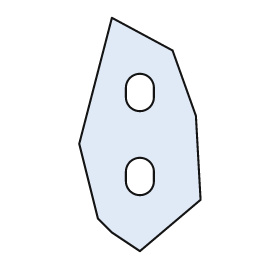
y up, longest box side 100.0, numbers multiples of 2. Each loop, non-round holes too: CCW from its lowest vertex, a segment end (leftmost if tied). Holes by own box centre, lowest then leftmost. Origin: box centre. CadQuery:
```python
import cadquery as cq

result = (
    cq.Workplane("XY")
    .moveTo(0.0, -50.0)
    .lineTo(26.0, -28.0)
    .lineTo(24.0, 8.0)
    .lineTo(14.0, 36.0)
    .lineTo(-12.0, 50.0)
    .lineTo(-26.0, -4.0)
    .lineTo(-18.0, -36.0)
    .lineTo(-12.0, -42.0)
    .close()
    .moveTo(-6.0, -20.0)
    .threePointArc((0.0, -26.0), (6.0, -20.0))
    .lineTo(6.0, -16.0)
    .threePointArc((0.0, -10.0), (-6.0, -16.0))
    .close()
    .moveTo(-6.0, 16.0)
    .threePointArc((0.0, 10.0), (6.0, 16.0))
    .lineTo(6.0, 20.0)
    .threePointArc((0.0, 26.0), (-6.0, 20.0))
    .close()
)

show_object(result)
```